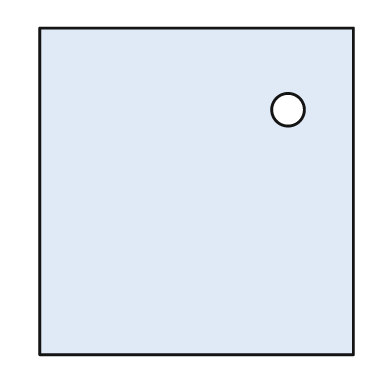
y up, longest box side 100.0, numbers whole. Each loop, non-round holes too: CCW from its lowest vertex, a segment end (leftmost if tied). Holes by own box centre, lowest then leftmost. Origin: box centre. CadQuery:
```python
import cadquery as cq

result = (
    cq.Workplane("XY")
    .moveTo(-48.0, -50.0)
    .lineTo(48.0, -50.0)
    .lineTo(48.0, 50.0)
    .lineTo(-48.0, 50.0)
    .close()
    .moveTo(28.0, 25.0)
    .circle(5.0)
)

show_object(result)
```